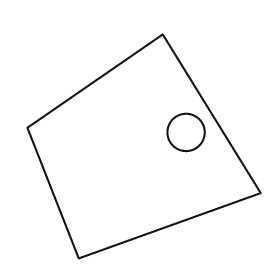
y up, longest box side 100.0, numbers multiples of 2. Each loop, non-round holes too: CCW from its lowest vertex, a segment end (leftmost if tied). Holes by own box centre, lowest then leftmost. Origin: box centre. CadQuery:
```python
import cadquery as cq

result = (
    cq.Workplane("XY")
    .moveTo(-28.0, -48.0)
    .lineTo(50.0, -20.0)
    .lineTo(8.0, 48.0)
    .lineTo(-50.0, 8.0)
    .close()
    .moveTo(18.0, 6.0)
    .circle(8.0)
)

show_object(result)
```